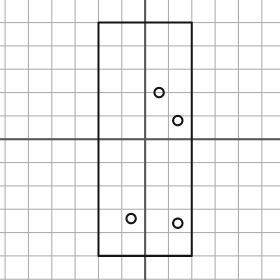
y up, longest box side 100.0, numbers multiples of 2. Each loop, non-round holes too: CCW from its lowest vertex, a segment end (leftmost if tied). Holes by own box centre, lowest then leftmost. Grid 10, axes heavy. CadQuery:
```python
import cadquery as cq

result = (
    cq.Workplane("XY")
    .moveTo(-20.0, -50.0)
    .lineTo(20.0, -50.0)
    .lineTo(20.0, 50.0)
    .lineTo(-20.0, 50.0)
    .close()
    .moveTo(14.0, -36.0)
    .circle(2.0)
    .moveTo(-6.0, -34.0)
    .circle(2.0)
    .moveTo(14.0, 8.0)
    .circle(2.0)
    .moveTo(6.0, 20.0)
    .circle(2.0)
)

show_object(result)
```